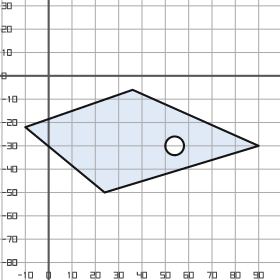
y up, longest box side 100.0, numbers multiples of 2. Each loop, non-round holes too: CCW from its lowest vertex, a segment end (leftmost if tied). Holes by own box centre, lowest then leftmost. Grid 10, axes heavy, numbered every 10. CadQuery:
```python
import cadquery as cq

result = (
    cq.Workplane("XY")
    .moveTo(24.0, -50.0)
    .lineTo(90.0, -30.0)
    .lineTo(36.0, -6.0)
    .lineTo(-10.0, -22.0)
    .close()
    .moveTo(54.0, -30.0)
    .circle(4.0)
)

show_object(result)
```